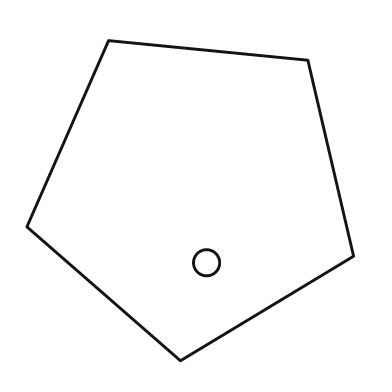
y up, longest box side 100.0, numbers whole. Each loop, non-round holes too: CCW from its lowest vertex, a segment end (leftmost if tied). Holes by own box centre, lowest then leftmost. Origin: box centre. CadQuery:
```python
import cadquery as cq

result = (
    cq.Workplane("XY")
    .moveTo(-3.0, -49.0)
    .lineTo(50.0, -17.0)
    .lineTo(36.0, 43.0)
    .lineTo(-25.0, 49.0)
    .lineTo(-50.0, -8.0)
    .close()
    .moveTo(5.0, -19.0)
    .circle(4.0)
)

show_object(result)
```